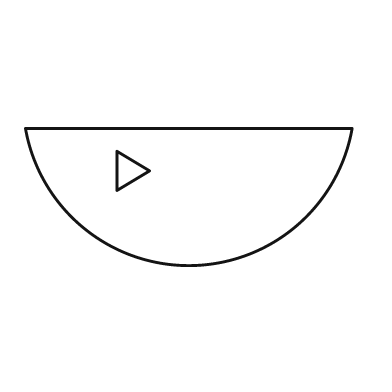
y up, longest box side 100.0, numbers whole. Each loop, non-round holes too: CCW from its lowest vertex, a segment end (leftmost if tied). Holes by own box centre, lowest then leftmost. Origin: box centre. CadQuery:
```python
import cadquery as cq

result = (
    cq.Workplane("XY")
    .moveTo(-50.0, 21.0)
    .threePointArc((0.0, -21.0), (50.0, 21.0))
    .close()
    .moveTo(-22.0, 2.0)
    .lineTo(-12.0, 8.0)
    .lineTo(-22.0, 14.0)
    .close()
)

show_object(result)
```